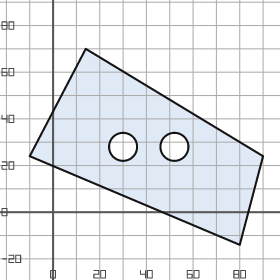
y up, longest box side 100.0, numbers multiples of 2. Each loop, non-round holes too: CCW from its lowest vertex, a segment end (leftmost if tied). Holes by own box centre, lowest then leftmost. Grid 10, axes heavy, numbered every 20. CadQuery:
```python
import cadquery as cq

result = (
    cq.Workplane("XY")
    .moveTo(80.0, -14.0)
    .lineTo(90.0, 24.0)
    .lineTo(14.0, 70.0)
    .lineTo(-10.0, 24.0)
    .close()
    .moveTo(30.0, 28.0)
    .circle(6.0)
    .moveTo(52.0, 28.0)
    .circle(6.0)
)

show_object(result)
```